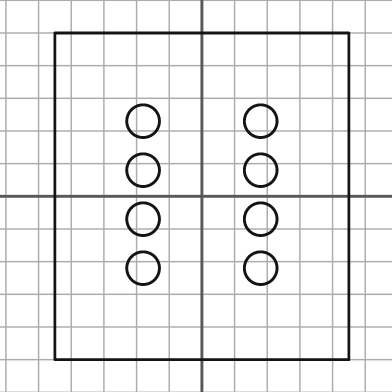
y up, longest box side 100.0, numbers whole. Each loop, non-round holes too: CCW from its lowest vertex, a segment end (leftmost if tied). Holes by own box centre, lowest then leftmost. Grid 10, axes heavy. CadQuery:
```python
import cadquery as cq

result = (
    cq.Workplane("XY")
    .moveTo(-45.0, -50.0)
    .lineTo(45.0, -50.0)
    .lineTo(45.0, 50.0)
    .lineTo(-45.0, 50.0)
    .close()
    .moveTo(-18.0, -22.0)
    .circle(5.0)
    .moveTo(18.0, -22.0)
    .circle(5.0)
    .moveTo(-18.0, -7.0)
    .circle(5.0)
    .moveTo(18.0, -7.0)
    .circle(5.0)
    .moveTo(-18.0, 8.0)
    .circle(5.0)
    .moveTo(18.0, 8.0)
    .circle(5.0)
    .moveTo(-18.0, 23.0)
    .circle(5.0)
    .moveTo(18.0, 23.0)
    .circle(5.0)
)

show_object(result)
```